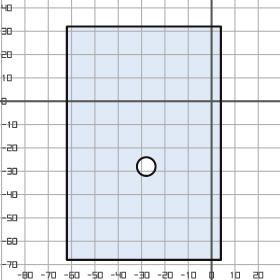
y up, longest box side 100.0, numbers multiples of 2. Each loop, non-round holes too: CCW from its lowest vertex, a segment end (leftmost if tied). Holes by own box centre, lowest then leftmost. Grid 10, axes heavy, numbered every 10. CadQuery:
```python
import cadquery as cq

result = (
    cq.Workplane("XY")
    .moveTo(-62.0, -68.0)
    .lineTo(4.0, -68.0)
    .lineTo(4.0, 32.0)
    .lineTo(-62.0, 32.0)
    .close()
    .moveTo(-28.0, -28.0)
    .circle(4.0)
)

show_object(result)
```